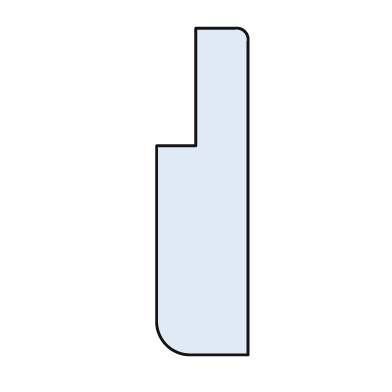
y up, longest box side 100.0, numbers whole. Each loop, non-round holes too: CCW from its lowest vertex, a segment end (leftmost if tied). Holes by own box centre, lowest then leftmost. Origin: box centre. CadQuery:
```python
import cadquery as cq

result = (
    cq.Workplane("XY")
    .moveTo(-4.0, -50.0)
    .lineTo(14.0, -50.0)
    .lineTo(14.0, 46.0)
    .threePointArc((13.0, 49.0), (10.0, 50.0))
    .lineTo(-2.0, 50.0)
    .lineTo(-2.0, 14.0)
    .lineTo(-14.0, 14.0)
    .lineTo(-14.0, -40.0)
    .threePointArc((-11.0, -47.0), (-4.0, -50.0))
    .close()
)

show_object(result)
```